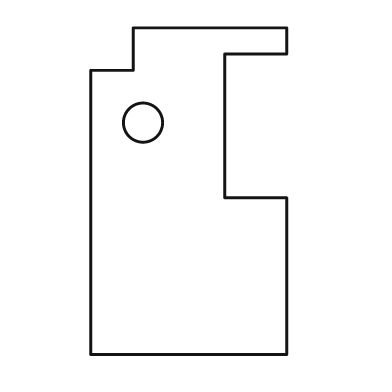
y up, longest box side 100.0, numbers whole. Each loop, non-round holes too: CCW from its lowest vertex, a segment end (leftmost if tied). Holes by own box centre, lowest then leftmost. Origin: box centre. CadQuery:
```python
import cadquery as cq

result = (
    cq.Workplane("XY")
    .moveTo(-30.0, -50.0)
    .lineTo(30.0, -50.0)
    .lineTo(30.0, -2.0)
    .lineTo(11.0, -2.0)
    .lineTo(11.0, 42.0)
    .lineTo(30.0, 42.0)
    .lineTo(30.0, 50.0)
    .lineTo(-17.0, 50.0)
    .lineTo(-17.0, 37.0)
    .lineTo(-30.0, 37.0)
    .close()
    .moveTo(-14.0, 21.0)
    .circle(6.0)
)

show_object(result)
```